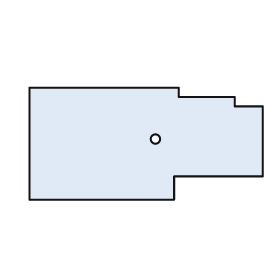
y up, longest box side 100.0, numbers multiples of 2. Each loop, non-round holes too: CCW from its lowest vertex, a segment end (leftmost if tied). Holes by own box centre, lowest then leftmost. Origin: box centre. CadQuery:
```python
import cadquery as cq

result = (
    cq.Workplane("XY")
    .moveTo(-50.0, -24.0)
    .lineTo(12.0, -24.0)
    .lineTo(12.0, -14.0)
    .lineTo(50.0, -14.0)
    .lineTo(50.0, 16.0)
    .lineTo(38.0, 16.0)
    .lineTo(38.0, 20.0)
    .lineTo(14.0, 20.0)
    .lineTo(14.0, 24.0)
    .lineTo(-50.0, 24.0)
    .close()
    .moveTo(4.0, 2.0)
    .circle(2.0)
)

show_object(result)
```